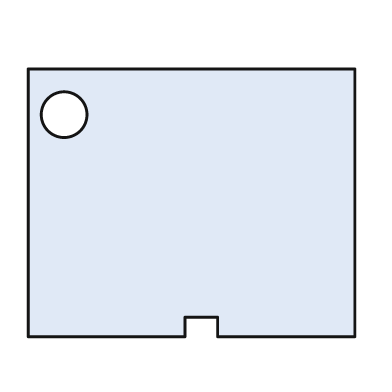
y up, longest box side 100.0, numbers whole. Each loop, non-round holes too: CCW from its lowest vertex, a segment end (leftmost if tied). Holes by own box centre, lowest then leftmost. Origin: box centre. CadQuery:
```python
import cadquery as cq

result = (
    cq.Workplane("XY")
    .moveTo(-50.0, -41.0)
    .lineTo(-2.0, -41.0)
    .lineTo(-2.0, -35.0)
    .lineTo(8.0, -35.0)
    .lineTo(8.0, -41.0)
    .lineTo(50.0, -41.0)
    .lineTo(50.0, 41.0)
    .lineTo(-50.0, 41.0)
    .close()
    .moveTo(-39.0, 27.0)
    .circle(7.0)
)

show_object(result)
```